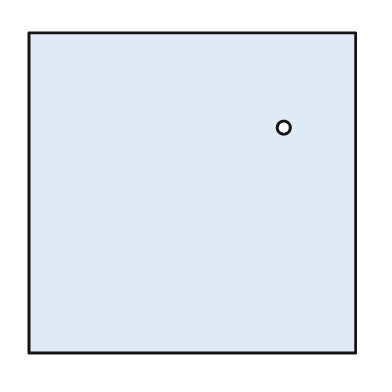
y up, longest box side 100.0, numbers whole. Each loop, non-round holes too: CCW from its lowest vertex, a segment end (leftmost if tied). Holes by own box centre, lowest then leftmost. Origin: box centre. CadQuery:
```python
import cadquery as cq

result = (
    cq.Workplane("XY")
    .moveTo(-50.0, -49.0)
    .lineTo(50.0, -49.0)
    .lineTo(50.0, 49.0)
    .lineTo(-50.0, 49.0)
    .close()
    .moveTo(28.0, 20.0)
    .circle(2.0)
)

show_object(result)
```